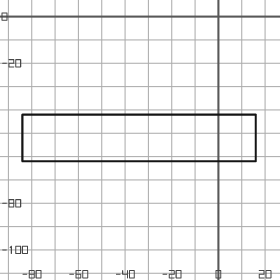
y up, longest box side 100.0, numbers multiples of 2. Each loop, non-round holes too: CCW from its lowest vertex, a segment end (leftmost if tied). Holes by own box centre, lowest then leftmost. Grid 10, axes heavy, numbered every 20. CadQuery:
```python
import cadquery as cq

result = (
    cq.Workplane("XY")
    .moveTo(-84.0, -62.0)
    .lineTo(16.0, -62.0)
    .lineTo(16.0, -42.0)
    .lineTo(-84.0, -42.0)
    .close()
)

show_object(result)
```